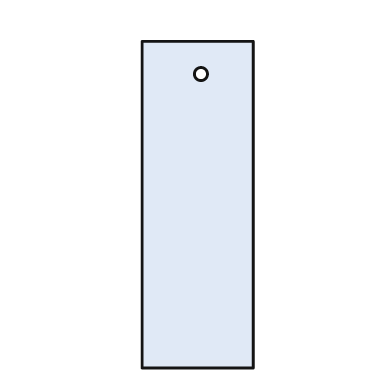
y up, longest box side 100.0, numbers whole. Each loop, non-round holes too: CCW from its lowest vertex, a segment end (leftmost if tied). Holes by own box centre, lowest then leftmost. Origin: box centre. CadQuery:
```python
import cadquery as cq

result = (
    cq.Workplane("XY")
    .moveTo(-17.0, -50.0)
    .lineTo(17.0, -50.0)
    .lineTo(17.0, 50.0)
    .lineTo(-17.0, 50.0)
    .close()
    .moveTo(1.0, 40.0)
    .circle(2.0)
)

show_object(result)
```